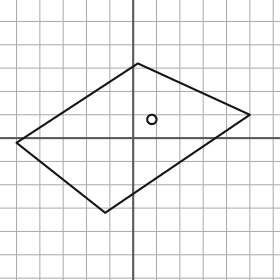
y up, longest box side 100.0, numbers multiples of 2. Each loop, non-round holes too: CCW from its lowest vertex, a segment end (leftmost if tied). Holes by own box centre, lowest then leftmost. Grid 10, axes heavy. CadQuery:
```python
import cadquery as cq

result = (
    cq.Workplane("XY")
    .moveTo(-12.0, -32.0)
    .lineTo(50.0, 10.0)
    .lineTo(2.0, 32.0)
    .lineTo(-50.0, -2.0)
    .close()
    .moveTo(8.0, 8.0)
    .circle(2.0)
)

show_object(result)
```